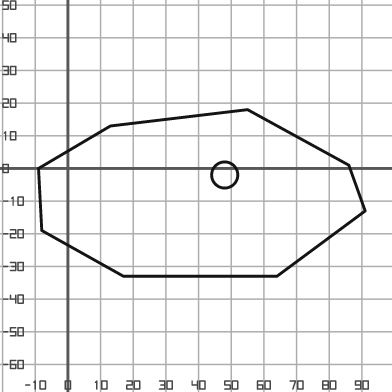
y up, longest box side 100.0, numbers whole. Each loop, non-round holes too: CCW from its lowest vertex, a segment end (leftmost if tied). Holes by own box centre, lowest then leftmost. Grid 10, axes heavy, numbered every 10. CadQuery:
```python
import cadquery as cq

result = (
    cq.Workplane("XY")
    .moveTo(17.0, -33.0)
    .lineTo(64.0, -33.0)
    .lineTo(91.0, -13.0)
    .lineTo(86.0, 1.0)
    .lineTo(55.0, 18.0)
    .lineTo(13.0, 13.0)
    .lineTo(-9.0, 0.0)
    .lineTo(-8.0, -19.0)
    .close()
    .moveTo(48.0, -2.0)
    .circle(4.0)
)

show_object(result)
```